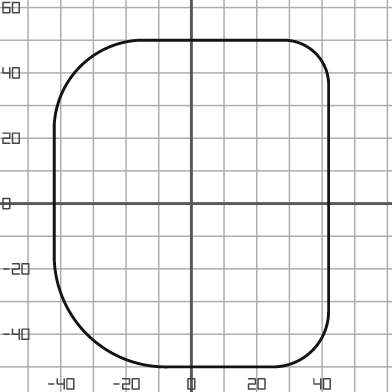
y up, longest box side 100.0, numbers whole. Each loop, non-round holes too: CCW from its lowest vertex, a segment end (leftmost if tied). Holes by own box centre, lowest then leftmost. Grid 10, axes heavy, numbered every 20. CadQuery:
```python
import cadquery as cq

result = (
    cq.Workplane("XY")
    .moveTo(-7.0, -50.0)
    .lineTo(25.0, -50.0)
    .threePointArc((37.0, -45.0), (42.0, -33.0))
    .lineTo(42.0, 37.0)
    .threePointArc((38.0, 46.0), (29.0, 50.0))
    .lineTo(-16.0, 50.0)
    .threePointArc((-34.0, 42.0), (-42.0, 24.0))
    .lineTo(-42.0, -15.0)
    .threePointArc((-32.0, -40.0), (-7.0, -50.0))
    .close()
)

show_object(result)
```